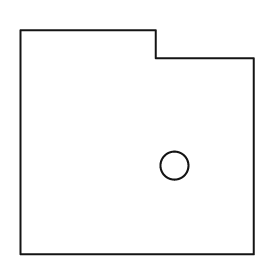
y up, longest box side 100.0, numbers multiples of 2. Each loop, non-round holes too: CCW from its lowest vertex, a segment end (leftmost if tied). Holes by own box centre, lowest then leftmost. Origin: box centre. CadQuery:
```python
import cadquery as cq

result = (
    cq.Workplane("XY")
    .moveTo(-50.0, -48.0)
    .lineTo(50.0, -48.0)
    .lineTo(50.0, 36.0)
    .lineTo(8.0, 36.0)
    .lineTo(8.0, 48.0)
    .lineTo(-50.0, 48.0)
    .close()
    .moveTo(16.0, -10.0)
    .circle(6.0)
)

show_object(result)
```